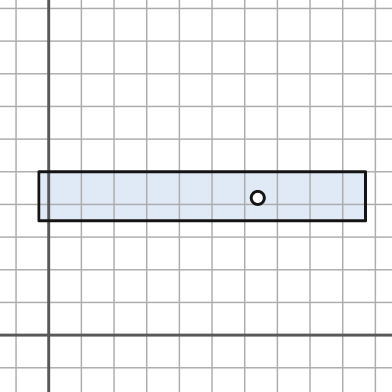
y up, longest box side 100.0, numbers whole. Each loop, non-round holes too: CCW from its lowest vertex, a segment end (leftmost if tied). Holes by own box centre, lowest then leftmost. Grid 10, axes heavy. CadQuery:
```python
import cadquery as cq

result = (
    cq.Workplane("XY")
    .moveTo(-3.0, 35.0)
    .lineTo(97.0, 35.0)
    .lineTo(97.0, 50.0)
    .lineTo(-3.0, 50.0)
    .close()
    .moveTo(64.0, 42.0)
    .circle(2.0)
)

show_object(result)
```